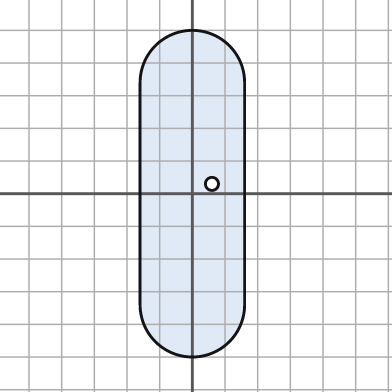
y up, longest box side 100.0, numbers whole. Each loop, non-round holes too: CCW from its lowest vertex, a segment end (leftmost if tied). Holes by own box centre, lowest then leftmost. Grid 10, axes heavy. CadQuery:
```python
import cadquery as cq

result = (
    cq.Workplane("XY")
    .moveTo(-16.0, -34.0)
    .threePointArc((0.0, -50.0), (16.0, -34.0))
    .lineTo(16.0, 34.0)
    .threePointArc((0.0, 50.0), (-16.0, 34.0))
    .close()
    .moveTo(6.0, 3.0)
    .circle(2.0)
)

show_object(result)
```